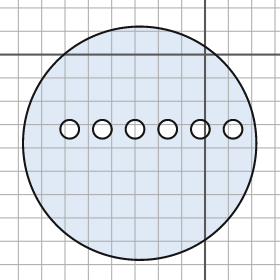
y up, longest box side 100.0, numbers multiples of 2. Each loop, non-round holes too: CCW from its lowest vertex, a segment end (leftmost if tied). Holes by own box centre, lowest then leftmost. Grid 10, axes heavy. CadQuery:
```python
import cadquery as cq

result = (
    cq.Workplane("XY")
    .moveTo(-28.0, -38.0)
    .circle(50.0)
    .moveTo(-58.0, -32.0)
    .circle(4.0)
    .moveTo(-44.0, -32.0)
    .circle(4.0)
    .moveTo(-30.0, -32.0)
    .circle(4.0)
    .moveTo(-16.0, -32.0)
    .circle(4.0)
    .moveTo(-2.0, -32.0)
    .circle(4.0)
    .moveTo(12.0, -32.0)
    .circle(4.0)
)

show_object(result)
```